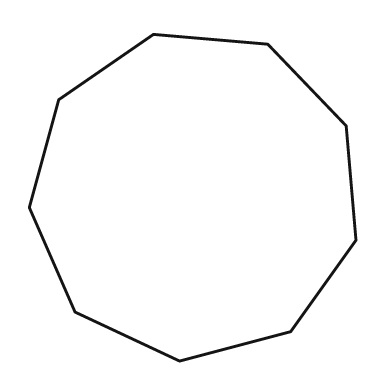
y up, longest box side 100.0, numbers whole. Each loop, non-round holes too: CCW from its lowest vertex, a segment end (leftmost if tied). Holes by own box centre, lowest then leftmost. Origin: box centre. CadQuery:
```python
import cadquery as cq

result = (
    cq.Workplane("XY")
    .moveTo(-4.0, -50.0)
    .lineTo(30.0, -41.0)
    .lineTo(50.0, -13.0)
    .lineTo(47.0, 22.0)
    .lineTo(23.0, 47.0)
    .lineTo(-12.0, 50.0)
    .lineTo(-41.0, 30.0)
    .lineTo(-50.0, -3.0)
    .lineTo(-36.0, -35.0)
    .close()
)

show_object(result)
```